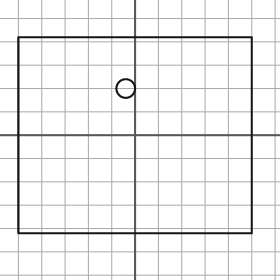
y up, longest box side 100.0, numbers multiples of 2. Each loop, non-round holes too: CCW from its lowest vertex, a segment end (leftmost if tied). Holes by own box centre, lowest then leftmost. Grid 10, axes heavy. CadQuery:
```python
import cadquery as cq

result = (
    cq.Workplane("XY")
    .moveTo(-50.0, -42.0)
    .lineTo(50.0, -42.0)
    .lineTo(50.0, 42.0)
    .lineTo(-50.0, 42.0)
    .close()
    .moveTo(-4.0, 20.0)
    .circle(4.0)
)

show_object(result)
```